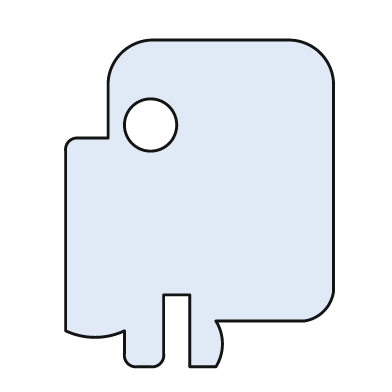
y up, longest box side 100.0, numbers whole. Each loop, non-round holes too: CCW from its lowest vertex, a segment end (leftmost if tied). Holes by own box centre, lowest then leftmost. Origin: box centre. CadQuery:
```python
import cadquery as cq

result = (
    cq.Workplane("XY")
    .moveTo(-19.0, -50.0)
    .lineTo(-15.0, -50.0)
    .threePointArc((-12.0, -49.0), (-11.0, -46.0))
    .lineTo(-11.0, -28.0)
    .lineTo(-3.0, -28.0)
    .lineTo(-3.0, -50.0)
    .lineTo(5.0, -50.0)
    .threePointArc((7.0, -43.0), (5.0, -36.0))
    .lineTo(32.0, -36.0)
    .threePointArc((38.0, -33.0), (41.0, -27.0))
    .lineTo(41.0, 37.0)
    .threePointArc((37.0, 46.0), (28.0, 50.0))
    .lineTo(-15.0, 50.0)
    .threePointArc((-24.0, 46.0), (-28.0, 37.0))
    .lineTo(-28.0, 20.0)
    .lineTo(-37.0, 20.0)
    .threePointArc((-40.0, 19.0), (-41.0, 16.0))
    .lineTo(-41.0, -39.0)
    .threePointArc((-32.0, -41.0), (-23.0, -39.0))
    .lineTo(-23.0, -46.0)
    .threePointArc((-22.0, -49.0), (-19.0, -50.0))
    .close()
    .moveTo(-15.0, 24.0)
    .circle(8.0)
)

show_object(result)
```